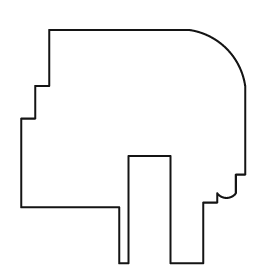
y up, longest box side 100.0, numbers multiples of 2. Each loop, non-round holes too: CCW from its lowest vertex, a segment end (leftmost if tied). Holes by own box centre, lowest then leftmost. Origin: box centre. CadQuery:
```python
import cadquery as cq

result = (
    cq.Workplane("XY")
    .moveTo(-6.0, -50.0)
    .lineTo(-2.0, -50.0)
    .lineTo(-2.0, -4.0)
    .lineTo(16.0, -4.0)
    .lineTo(16.0, -50.0)
    .lineTo(30.0, -50.0)
    .lineTo(30.0, -24.0)
    .lineTo(36.0, -24.0)
    .lineTo(36.0, -20.0)
    .threePointArc((40.0, -22.0), (44.0, -20.0))
    .lineTo(44.0, -12.0)
    .lineTo(48.0, -12.0)
    .lineTo(48.0, 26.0)
    .threePointArc((40.0, 42.0), (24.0, 50.0))
    .lineTo(-36.0, 50.0)
    .lineTo(-36.0, 26.0)
    .lineTo(-42.0, 26.0)
    .lineTo(-42.0, 12.0)
    .lineTo(-48.0, 12.0)
    .lineTo(-48.0, -26.0)
    .lineTo(-6.0, -26.0)
    .close()
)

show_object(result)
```